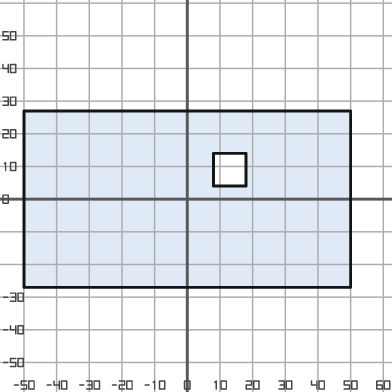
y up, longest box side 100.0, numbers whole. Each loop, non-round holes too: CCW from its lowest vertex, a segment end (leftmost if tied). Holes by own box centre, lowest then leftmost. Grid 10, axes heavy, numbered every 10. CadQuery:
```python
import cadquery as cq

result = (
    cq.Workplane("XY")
    .moveTo(-50.0, -27.0)
    .lineTo(50.0, -27.0)
    .lineTo(50.0, 27.0)
    .lineTo(-50.0, 27.0)
    .close()
    .moveTo(8.0, 4.0)
    .lineTo(18.0, 4.0)
    .lineTo(18.0, 14.0)
    .lineTo(8.0, 14.0)
    .close()
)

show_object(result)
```